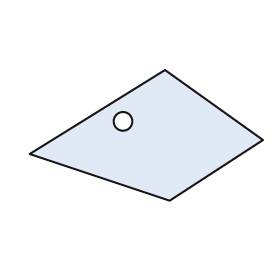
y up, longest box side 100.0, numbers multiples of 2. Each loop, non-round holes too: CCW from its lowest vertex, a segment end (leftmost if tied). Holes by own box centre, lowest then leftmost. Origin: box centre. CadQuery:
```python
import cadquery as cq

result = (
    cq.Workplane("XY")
    .moveTo(10.0, -28.0)
    .lineTo(50.0, -2.0)
    .lineTo(8.0, 28.0)
    .lineTo(-50.0, -8.0)
    .close()
    .moveTo(-10.0, 6.0)
    .circle(4.0)
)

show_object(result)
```